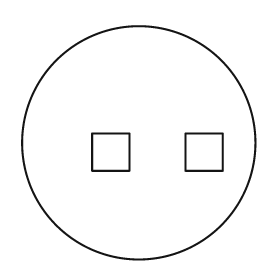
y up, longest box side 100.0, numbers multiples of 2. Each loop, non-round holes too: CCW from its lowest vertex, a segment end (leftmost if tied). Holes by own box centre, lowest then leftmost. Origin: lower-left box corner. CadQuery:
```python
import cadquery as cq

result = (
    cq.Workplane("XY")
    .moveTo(50.0, 50.0)
    .circle(50.0)
    .moveTo(30.0, 38.0)
    .lineTo(46.0, 38.0)
    .lineTo(46.0, 54.0)
    .lineTo(30.0, 54.0)
    .close()
    .moveTo(70.0, 38.0)
    .lineTo(86.0, 38.0)
    .lineTo(86.0, 54.0)
    .lineTo(70.0, 54.0)
    .close()
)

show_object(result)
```